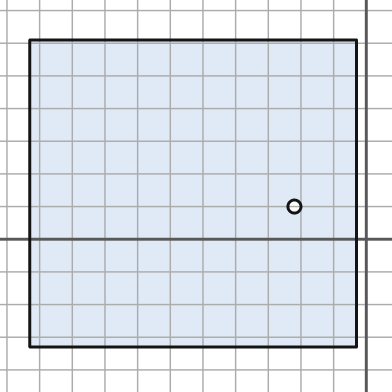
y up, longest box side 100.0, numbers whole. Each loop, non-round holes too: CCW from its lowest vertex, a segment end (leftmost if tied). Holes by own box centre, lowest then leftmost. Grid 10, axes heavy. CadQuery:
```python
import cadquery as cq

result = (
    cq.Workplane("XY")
    .moveTo(-103.0, -33.0)
    .lineTo(-3.0, -33.0)
    .lineTo(-3.0, 61.0)
    .lineTo(-103.0, 61.0)
    .close()
    .moveTo(-22.0, 10.0)
    .circle(2.0)
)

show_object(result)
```